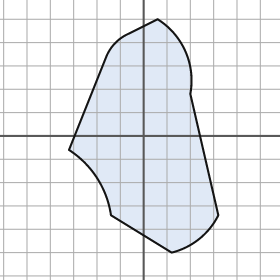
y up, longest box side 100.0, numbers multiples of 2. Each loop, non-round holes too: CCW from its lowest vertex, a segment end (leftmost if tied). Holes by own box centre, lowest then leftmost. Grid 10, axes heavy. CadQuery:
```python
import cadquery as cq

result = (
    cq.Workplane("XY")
    .moveTo(12.0, -50.0)
    .threePointArc((24.0, -44.0), (32.0, -34.0))
    .lineTo(20.0, 18.0)
    .threePointArc((18.0, 36.0), (6.0, 50.0))
    .lineTo(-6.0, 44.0)
    .threePointArc((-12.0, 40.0), (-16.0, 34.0))
    .lineTo(-32.0, -6.0)
    .threePointArc((-20.0, -18.0), (-14.0, -34.0))
    .close()
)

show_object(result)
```